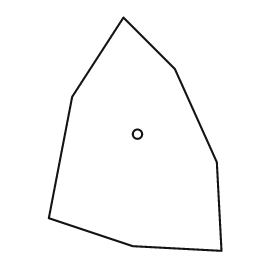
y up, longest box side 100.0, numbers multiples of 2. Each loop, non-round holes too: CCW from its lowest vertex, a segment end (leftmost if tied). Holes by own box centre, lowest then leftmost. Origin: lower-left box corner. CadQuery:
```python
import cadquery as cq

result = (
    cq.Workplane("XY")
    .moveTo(74.0, 0.0)
    .lineTo(72.0, 38.0)
    .lineTo(54.0, 78.0)
    .lineTo(32.0, 100.0)
    .lineTo(10.0, 66.0)
    .lineTo(0.0, 14.0)
    .lineTo(36.0, 2.0)
    .close()
    .moveTo(38.0, 50.0)
    .circle(2.0)
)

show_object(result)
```